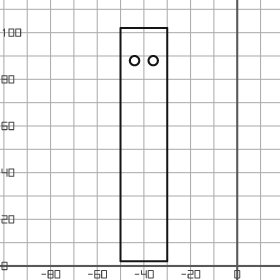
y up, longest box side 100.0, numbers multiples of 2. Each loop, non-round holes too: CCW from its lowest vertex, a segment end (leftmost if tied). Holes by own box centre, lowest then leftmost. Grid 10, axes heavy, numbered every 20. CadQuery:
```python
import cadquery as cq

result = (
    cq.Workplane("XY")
    .moveTo(-50.0, 2.0)
    .lineTo(-30.0, 2.0)
    .lineTo(-30.0, 102.0)
    .lineTo(-50.0, 102.0)
    .close()
    .moveTo(-44.0, 88.0)
    .circle(2.0)
    .moveTo(-36.0, 88.0)
    .circle(2.0)
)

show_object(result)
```